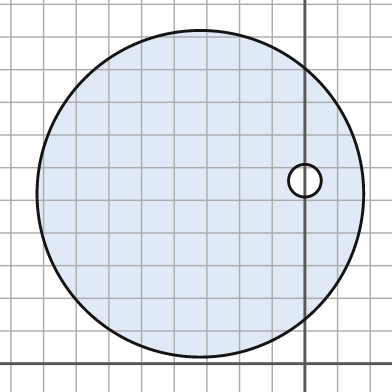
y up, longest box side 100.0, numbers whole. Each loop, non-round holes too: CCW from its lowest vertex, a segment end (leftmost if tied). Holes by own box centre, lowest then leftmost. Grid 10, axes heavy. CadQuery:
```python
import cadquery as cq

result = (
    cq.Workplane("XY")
    .moveTo(-32.0, 52.0)
    .circle(50.0)
    .moveTo(0.0, 56.0)
    .circle(5.0)
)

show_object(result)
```